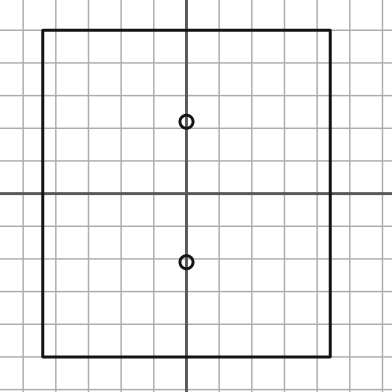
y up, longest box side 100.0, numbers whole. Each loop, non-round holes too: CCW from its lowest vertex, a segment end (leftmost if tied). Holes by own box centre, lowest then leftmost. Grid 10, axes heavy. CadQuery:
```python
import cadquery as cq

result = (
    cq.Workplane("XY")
    .moveTo(-44.0, -50.0)
    .lineTo(44.0, -50.0)
    .lineTo(44.0, 50.0)
    .lineTo(-44.0, 50.0)
    .close()
    .moveTo(0.0, -21.0)
    .circle(2.0)
    .moveTo(0.0, 22.0)
    .circle(2.0)
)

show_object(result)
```